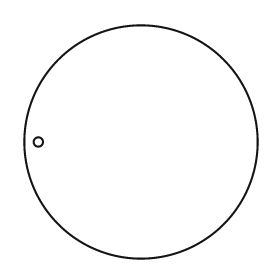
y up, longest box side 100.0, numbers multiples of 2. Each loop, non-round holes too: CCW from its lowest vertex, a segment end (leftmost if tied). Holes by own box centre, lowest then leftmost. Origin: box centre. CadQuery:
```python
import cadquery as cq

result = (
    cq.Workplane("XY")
    .moveTo(0.0, 0.0)
    .circle(50.0)
    .moveTo(-44.0, 0.0)
    .circle(2.0)
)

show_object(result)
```